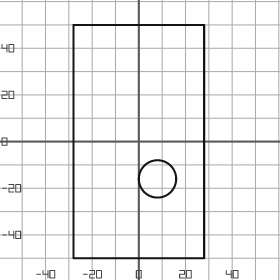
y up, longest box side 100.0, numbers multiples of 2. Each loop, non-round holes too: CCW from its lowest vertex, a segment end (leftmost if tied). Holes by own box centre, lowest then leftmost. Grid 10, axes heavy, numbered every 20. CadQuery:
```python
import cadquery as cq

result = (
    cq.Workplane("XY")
    .moveTo(-28.0, -50.0)
    .lineTo(28.0, -50.0)
    .lineTo(28.0, 50.0)
    .lineTo(-28.0, 50.0)
    .close()
    .moveTo(8.0, -16.0)
    .circle(8.0)
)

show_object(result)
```